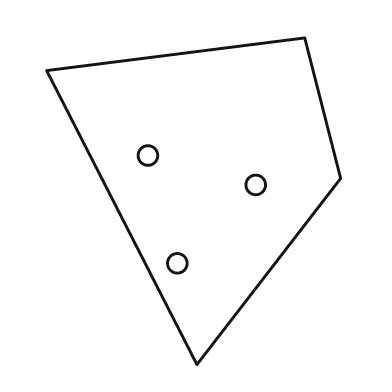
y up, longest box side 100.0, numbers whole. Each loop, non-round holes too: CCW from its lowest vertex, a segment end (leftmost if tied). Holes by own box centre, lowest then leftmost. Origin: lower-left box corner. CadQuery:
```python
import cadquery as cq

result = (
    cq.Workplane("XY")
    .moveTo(46.0, 0.0)
    .lineTo(90.0, 57.0)
    .lineTo(79.0, 100.0)
    .lineTo(0.0, 90.0)
    .close()
    .moveTo(40.0, 31.0)
    .circle(3.0)
    .moveTo(64.0, 55.0)
    .circle(3.0)
    .moveTo(31.0, 64.0)
    .circle(3.0)
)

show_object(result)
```